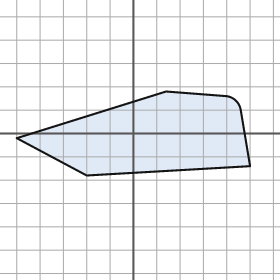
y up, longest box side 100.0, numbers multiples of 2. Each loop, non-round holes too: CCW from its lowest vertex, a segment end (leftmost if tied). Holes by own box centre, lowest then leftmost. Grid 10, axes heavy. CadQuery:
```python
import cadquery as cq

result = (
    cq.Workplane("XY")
    .moveTo(-20.0, -18.0)
    .lineTo(50.0, -14.0)
    .lineTo(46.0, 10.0)
    .threePointArc((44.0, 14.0), (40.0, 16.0))
    .lineTo(14.0, 18.0)
    .lineTo(-50.0, -2.0)
    .close()
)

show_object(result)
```